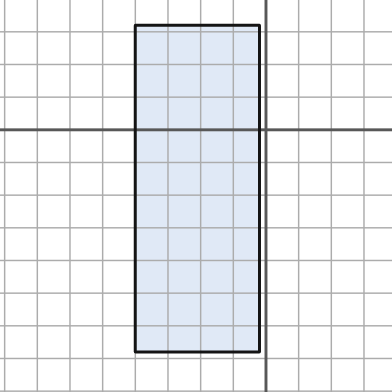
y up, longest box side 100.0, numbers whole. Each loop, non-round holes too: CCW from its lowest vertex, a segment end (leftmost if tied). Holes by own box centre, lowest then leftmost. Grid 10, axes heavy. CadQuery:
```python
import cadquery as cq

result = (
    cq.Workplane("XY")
    .moveTo(-40.0, -68.0)
    .lineTo(-2.0, -68.0)
    .lineTo(-2.0, 32.0)
    .lineTo(-40.0, 32.0)
    .close()
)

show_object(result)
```